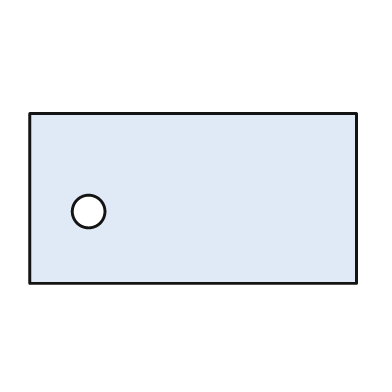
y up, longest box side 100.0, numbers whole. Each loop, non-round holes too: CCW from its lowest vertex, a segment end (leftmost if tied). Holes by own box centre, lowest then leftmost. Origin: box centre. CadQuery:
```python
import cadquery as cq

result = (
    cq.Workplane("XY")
    .moveTo(-50.0, -26.0)
    .lineTo(50.0, -26.0)
    .lineTo(50.0, 26.0)
    .lineTo(-50.0, 26.0)
    .close()
    .moveTo(-32.0, -4.0)
    .circle(5.0)
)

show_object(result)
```